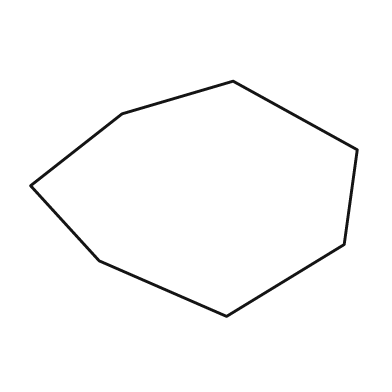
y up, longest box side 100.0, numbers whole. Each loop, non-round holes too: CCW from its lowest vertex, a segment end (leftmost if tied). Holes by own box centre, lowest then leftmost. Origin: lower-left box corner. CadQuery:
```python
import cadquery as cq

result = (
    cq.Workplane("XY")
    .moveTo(60.0, 0.0)
    .lineTo(96.0, 22.0)
    .lineTo(100.0, 51.0)
    .lineTo(62.0, 72.0)
    .lineTo(28.0, 62.0)
    .lineTo(0.0, 40.0)
    .lineTo(21.0, 17.0)
    .close()
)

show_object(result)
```